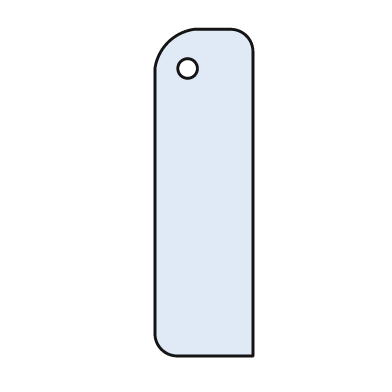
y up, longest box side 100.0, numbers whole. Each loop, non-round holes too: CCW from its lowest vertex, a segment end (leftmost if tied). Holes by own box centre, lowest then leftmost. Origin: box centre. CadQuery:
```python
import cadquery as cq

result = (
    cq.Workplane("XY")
    .moveTo(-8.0, -50.0)
    .lineTo(15.0, -50.0)
    .lineTo(15.0, 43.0)
    .threePointArc((13.0, 48.0), (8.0, 50.0))
    .lineTo(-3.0, 50.0)
    .threePointArc((-11.0, 46.0), (-15.0, 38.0))
    .lineTo(-15.0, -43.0)
    .threePointArc((-13.0, -48.0), (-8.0, -50.0))
    .close()
    .moveTo(-5.0, 38.0)
    .circle(3.0)
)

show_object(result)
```